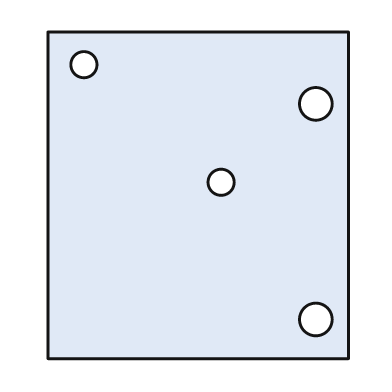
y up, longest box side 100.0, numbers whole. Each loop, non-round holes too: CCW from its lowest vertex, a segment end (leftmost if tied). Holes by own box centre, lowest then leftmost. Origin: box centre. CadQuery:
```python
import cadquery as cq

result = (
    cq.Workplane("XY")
    .moveTo(-46.0, -50.0)
    .lineTo(46.0, -50.0)
    .lineTo(46.0, 50.0)
    .lineTo(-46.0, 50.0)
    .close()
    .moveTo(36.0, -38.0)
    .circle(5.0)
    .moveTo(7.0, 4.0)
    .circle(4.0)
    .moveTo(36.0, 28.0)
    .circle(5.0)
    .moveTo(-35.0, 40.0)
    .circle(4.0)
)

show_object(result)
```